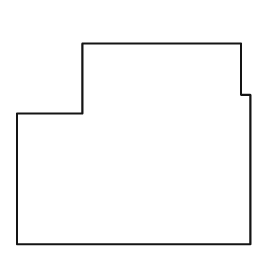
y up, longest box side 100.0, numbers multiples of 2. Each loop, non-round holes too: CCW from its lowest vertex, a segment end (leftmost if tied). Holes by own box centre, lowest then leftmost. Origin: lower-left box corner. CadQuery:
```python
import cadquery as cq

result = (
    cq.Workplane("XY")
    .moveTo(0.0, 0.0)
    .lineTo(100.0, 0.0)
    .lineTo(100.0, 64.0)
    .lineTo(96.0, 64.0)
    .lineTo(96.0, 86.0)
    .lineTo(28.0, 86.0)
    .lineTo(28.0, 56.0)
    .lineTo(0.0, 56.0)
    .close()
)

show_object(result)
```